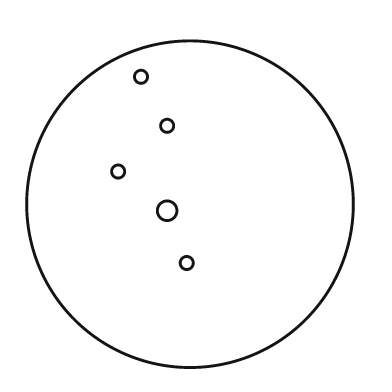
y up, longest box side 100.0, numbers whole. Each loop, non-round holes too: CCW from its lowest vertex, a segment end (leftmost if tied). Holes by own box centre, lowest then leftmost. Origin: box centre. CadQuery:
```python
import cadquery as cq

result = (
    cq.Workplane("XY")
    .moveTo(0.0, 0.0)
    .circle(50.0)
    .moveTo(-1.0, -18.0)
    .circle(2.0)
    .moveTo(-7.0, -2.0)
    .circle(3.0)
    .moveTo(-22.0, 10.0)
    .circle(2.0)
    .moveTo(-7.0, 24.0)
    .circle(2.0)
    .moveTo(-15.0, 39.0)
    .circle(2.0)
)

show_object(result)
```